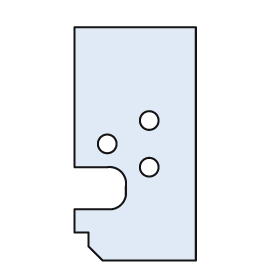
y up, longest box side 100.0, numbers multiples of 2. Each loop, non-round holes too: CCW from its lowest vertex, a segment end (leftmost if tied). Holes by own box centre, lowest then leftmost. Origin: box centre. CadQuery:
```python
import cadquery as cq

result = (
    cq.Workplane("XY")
    .moveTo(-14.0, -50.0)
    .lineTo(26.0, -50.0)
    .lineTo(26.0, 50.0)
    .lineTo(-26.0, 50.0)
    .lineTo(-26.0, -10.0)
    .lineTo(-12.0, -10.0)
    .threePointArc((-6.0, -12.0), (-4.0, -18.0))
    .lineTo(-4.0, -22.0)
    .threePointArc((-6.0, -26.0), (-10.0, -28.0))
    .lineTo(-26.0, -28.0)
    .lineTo(-26.0, -38.0)
    .lineTo(-20.0, -38.0)
    .lineTo(-20.0, -44.0)
    .close()
    .moveTo(6.0, -10.0)
    .circle(4.0)
    .moveTo(-12.0, 0.0)
    .circle(4.0)
    .moveTo(6.0, 10.0)
    .circle(4.0)
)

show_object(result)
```